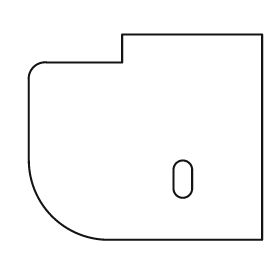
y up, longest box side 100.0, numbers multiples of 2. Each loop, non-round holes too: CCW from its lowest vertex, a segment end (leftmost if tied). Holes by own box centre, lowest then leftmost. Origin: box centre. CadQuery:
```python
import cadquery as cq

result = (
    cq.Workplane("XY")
    .moveTo(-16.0, -44.0)
    .lineTo(50.0, -44.0)
    .lineTo(50.0, 44.0)
    .lineTo(-10.0, 44.0)
    .lineTo(-10.0, 32.0)
    .lineTo(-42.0, 32.0)
    .threePointArc((-48.0, 30.0), (-50.0, 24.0))
    .lineTo(-50.0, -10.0)
    .threePointArc((-40.0, -34.0), (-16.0, -44.0))
    .close()
    .moveTo(12.0, -22.0)
    .threePointArc((16.0, -26.0), (20.0, -22.0))
    .lineTo(20.0, -14.0)
    .threePointArc((16.0, -10.0), (12.0, -14.0))
    .close()
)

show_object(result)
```